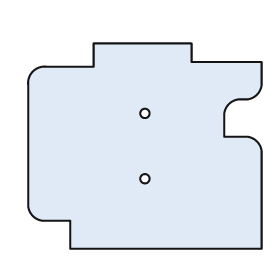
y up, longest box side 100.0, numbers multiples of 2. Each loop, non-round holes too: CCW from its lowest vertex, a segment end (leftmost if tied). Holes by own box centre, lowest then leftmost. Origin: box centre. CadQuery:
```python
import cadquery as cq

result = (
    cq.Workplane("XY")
    .moveTo(-32.0, -44.0)
    .lineTo(50.0, -44.0)
    .lineTo(50.0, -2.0)
    .threePointArc((48.0, 2.0), (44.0, 4.0))
    .lineTo(34.0, 4.0)
    .lineTo(34.0, 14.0)
    .threePointArc((36.0, 18.0), (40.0, 20.0))
    .lineTo(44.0, 20.0)
    .threePointArc((48.0, 22.0), (50.0, 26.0))
    .lineTo(50.0, 36.0)
    .lineTo(20.0, 36.0)
    .lineTo(20.0, 44.0)
    .lineTo(-22.0, 44.0)
    .lineTo(-22.0, 34.0)
    .lineTo(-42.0, 34.0)
    .threePointArc((-48.0, 32.0), (-50.0, 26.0))
    .lineTo(-50.0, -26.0)
    .threePointArc((-48.0, -30.0), (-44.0, -32.0))
    .lineTo(-32.0, -32.0)
    .close()
    .moveTo(0.0, -14.0)
    .circle(2.0)
    .moveTo(0.0, 14.0)
    .circle(2.0)
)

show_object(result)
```